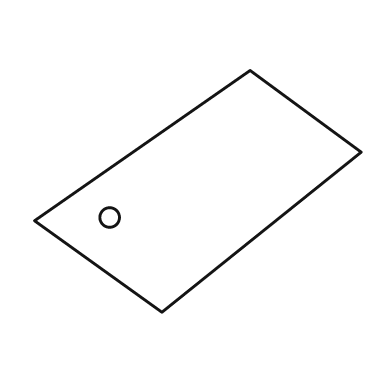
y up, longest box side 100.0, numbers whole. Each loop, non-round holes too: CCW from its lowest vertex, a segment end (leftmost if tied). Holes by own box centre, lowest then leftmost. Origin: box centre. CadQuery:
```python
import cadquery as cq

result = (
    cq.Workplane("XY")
    .moveTo(-11.0, -37.0)
    .lineTo(50.0, 12.0)
    .lineTo(16.0, 37.0)
    .lineTo(-50.0, -9.0)
    .close()
    .moveTo(-27.0, -8.0)
    .circle(3.0)
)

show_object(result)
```